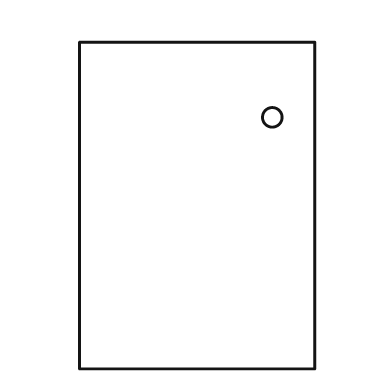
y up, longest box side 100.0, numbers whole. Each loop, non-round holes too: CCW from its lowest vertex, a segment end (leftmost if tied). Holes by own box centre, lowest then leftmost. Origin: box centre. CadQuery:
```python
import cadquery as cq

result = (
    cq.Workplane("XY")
    .moveTo(-36.0, -50.0)
    .lineTo(36.0, -50.0)
    .lineTo(36.0, 50.0)
    .lineTo(-36.0, 50.0)
    .close()
    .moveTo(23.0, 27.0)
    .circle(3.0)
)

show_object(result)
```